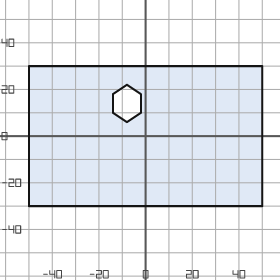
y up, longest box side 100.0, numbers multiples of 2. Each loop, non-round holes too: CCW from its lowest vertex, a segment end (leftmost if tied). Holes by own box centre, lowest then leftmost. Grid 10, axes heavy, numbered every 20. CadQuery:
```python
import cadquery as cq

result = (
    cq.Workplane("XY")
    .moveTo(-50.0, -30.0)
    .lineTo(50.0, -30.0)
    .lineTo(50.0, 30.0)
    .lineTo(-50.0, 30.0)
    .close()
    .moveTo(-8.0, 6.0)
    .lineTo(-2.0, 10.0)
    .lineTo(-2.0, 18.0)
    .lineTo(-8.0, 22.0)
    .lineTo(-14.0, 18.0)
    .lineTo(-14.0, 10.0)
    .close()
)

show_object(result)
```